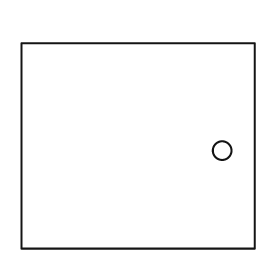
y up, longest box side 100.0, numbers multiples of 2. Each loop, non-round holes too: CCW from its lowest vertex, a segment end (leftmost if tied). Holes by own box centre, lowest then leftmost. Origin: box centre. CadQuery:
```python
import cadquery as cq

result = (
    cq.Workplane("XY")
    .moveTo(-50.0, -44.0)
    .lineTo(50.0, -44.0)
    .lineTo(50.0, 44.0)
    .lineTo(-50.0, 44.0)
    .close()
    .moveTo(36.0, -2.0)
    .circle(4.0)
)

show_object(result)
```